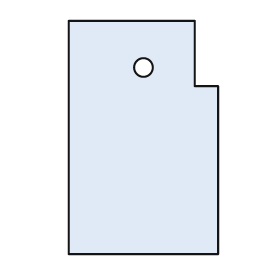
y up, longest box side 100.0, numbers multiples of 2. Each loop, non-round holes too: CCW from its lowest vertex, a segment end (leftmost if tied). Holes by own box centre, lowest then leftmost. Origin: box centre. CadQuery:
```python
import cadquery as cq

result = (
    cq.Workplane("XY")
    .moveTo(-32.0, -50.0)
    .lineTo(32.0, -50.0)
    .lineTo(32.0, 22.0)
    .lineTo(22.0, 22.0)
    .lineTo(22.0, 50.0)
    .lineTo(-32.0, 50.0)
    .close()
    .moveTo(0.0, 30.0)
    .circle(4.0)
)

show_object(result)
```